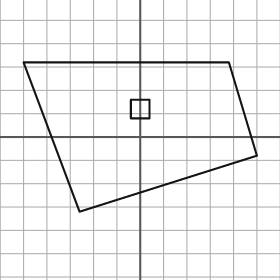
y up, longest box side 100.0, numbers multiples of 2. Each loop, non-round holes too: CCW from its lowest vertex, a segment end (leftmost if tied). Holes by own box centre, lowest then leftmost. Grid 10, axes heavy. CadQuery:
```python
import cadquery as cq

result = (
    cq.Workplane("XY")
    .moveTo(-26.0, -32.0)
    .lineTo(50.0, -8.0)
    .lineTo(38.0, 32.0)
    .lineTo(-50.0, 32.0)
    .close()
    .moveTo(-4.0, 8.0)
    .lineTo(4.0, 8.0)
    .lineTo(4.0, 16.0)
    .lineTo(-4.0, 16.0)
    .close()
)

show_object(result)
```